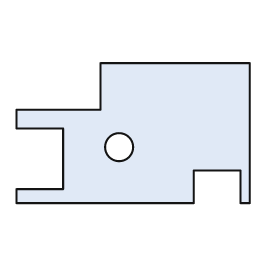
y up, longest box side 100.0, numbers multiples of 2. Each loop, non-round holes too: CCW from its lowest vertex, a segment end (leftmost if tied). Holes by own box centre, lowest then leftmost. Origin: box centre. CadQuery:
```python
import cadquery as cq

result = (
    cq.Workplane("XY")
    .moveTo(-50.0, -30.0)
    .lineTo(26.0, -30.0)
    .lineTo(26.0, -16.0)
    .lineTo(46.0, -16.0)
    .lineTo(46.0, -30.0)
    .lineTo(50.0, -30.0)
    .lineTo(50.0, 30.0)
    .lineTo(-14.0, 30.0)
    .lineTo(-14.0, 10.0)
    .lineTo(-50.0, 10.0)
    .lineTo(-50.0, 2.0)
    .lineTo(-30.0, 2.0)
    .lineTo(-30.0, -24.0)
    .lineTo(-50.0, -24.0)
    .close()
    .moveTo(-6.0, -6.0)
    .circle(6.0)
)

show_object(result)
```